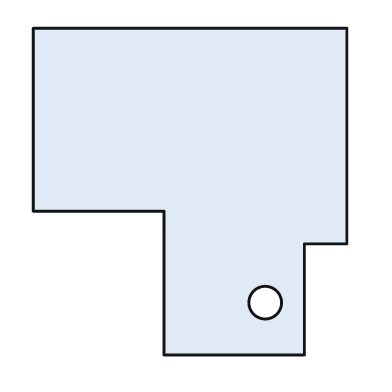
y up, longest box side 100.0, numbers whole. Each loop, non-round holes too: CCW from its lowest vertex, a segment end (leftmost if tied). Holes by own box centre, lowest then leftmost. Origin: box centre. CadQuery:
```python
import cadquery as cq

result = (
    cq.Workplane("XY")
    .moveTo(-8.0, -50.0)
    .lineTo(35.0, -50.0)
    .lineTo(35.0, -16.0)
    .lineTo(48.0, -16.0)
    .lineTo(48.0, 50.0)
    .lineTo(-48.0, 50.0)
    .lineTo(-48.0, -6.0)
    .lineTo(-8.0, -6.0)
    .close()
    .moveTo(23.0, -34.0)
    .circle(5.0)
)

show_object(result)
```